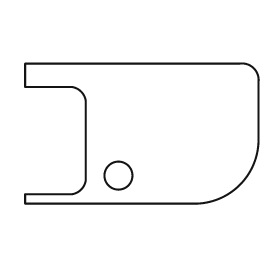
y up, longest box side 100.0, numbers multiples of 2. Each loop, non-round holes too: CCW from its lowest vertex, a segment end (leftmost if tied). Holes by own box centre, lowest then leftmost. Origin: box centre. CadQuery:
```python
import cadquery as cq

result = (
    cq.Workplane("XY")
    .moveTo(-50.0, -30.0)
    .lineTo(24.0, -30.0)
    .threePointArc((42.0, -22.0), (50.0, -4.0))
    .lineTo(50.0, 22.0)
    .threePointArc((48.0, 28.0), (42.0, 30.0))
    .lineTo(-50.0, 30.0)
    .lineTo(-50.0, 20.0)
    .lineTo(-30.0, 20.0)
    .threePointArc((-26.0, 18.0), (-24.0, 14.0))
    .lineTo(-24.0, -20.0)
    .threePointArc((-26.0, -24.0), (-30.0, -26.0))
    .lineTo(-50.0, -26.0)
    .close()
    .moveTo(-10.0, -18.0)
    .circle(6.0)
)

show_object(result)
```